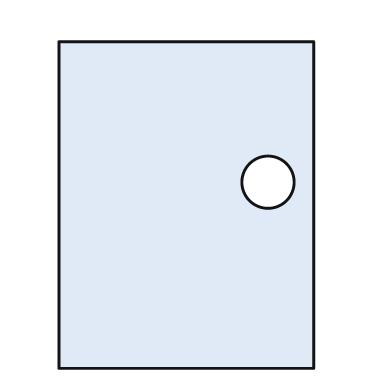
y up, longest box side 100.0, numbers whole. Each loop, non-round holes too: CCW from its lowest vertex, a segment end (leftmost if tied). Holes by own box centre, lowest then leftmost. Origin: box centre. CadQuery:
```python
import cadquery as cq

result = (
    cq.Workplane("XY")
    .moveTo(-39.0, -50.0)
    .lineTo(39.0, -50.0)
    .lineTo(39.0, 50.0)
    .lineTo(-39.0, 50.0)
    .close()
    .moveTo(25.0, 7.0)
    .circle(8.0)
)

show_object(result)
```